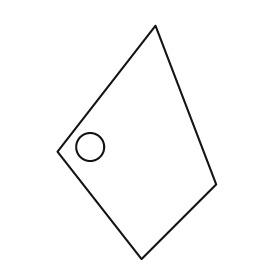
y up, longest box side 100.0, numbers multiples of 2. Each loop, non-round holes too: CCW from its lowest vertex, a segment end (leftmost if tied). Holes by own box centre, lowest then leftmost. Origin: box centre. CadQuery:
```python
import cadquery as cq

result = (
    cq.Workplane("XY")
    .moveTo(2.0, -50.0)
    .lineTo(34.0, -18.0)
    .lineTo(8.0, 50.0)
    .lineTo(-34.0, -4.0)
    .close()
    .moveTo(-20.0, -2.0)
    .circle(6.0)
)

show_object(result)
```